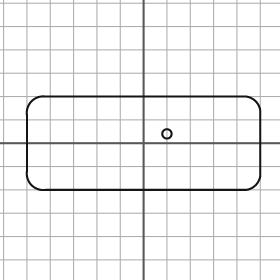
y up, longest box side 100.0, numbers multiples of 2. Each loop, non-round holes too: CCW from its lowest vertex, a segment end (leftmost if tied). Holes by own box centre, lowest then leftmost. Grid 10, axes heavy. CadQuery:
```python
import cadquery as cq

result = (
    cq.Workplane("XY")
    .moveTo(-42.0, -20.0)
    .lineTo(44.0, -20.0)
    .threePointArc((48.0, -18.0), (50.0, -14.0))
    .lineTo(50.0, 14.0)
    .threePointArc((48.0, 18.0), (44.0, 20.0))
    .lineTo(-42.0, 20.0)
    .threePointArc((-48.0, 18.0), (-50.0, 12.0))
    .lineTo(-50.0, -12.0)
    .threePointArc((-48.0, -18.0), (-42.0, -20.0))
    .close()
    .moveTo(10.0, 4.0)
    .circle(2.0)
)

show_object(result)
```